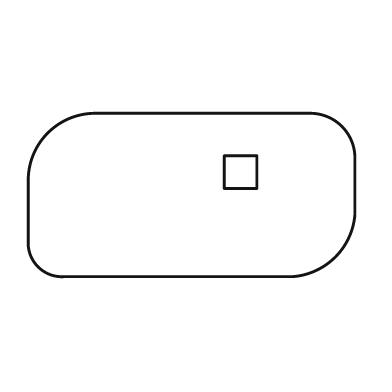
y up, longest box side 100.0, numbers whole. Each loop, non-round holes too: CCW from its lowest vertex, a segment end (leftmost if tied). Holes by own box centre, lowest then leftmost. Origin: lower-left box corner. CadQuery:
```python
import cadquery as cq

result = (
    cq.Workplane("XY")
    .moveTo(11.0, 0.0)
    .lineTo(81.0, 0.0)
    .threePointArc((94.0, 6.0), (100.0, 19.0))
    .lineTo(100.0, 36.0)
    .threePointArc((96.0, 46.0), (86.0, 50.0))
    .lineTo(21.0, 50.0)
    .threePointArc((6.0, 44.0), (0.0, 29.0))
    .lineTo(0.0, 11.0)
    .threePointArc((3.0, 3.0), (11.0, 0.0))
    .close()
    .moveTo(60.0, 27.0)
    .lineTo(70.0, 27.0)
    .lineTo(70.0, 37.0)
    .lineTo(60.0, 37.0)
    .close()
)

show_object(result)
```